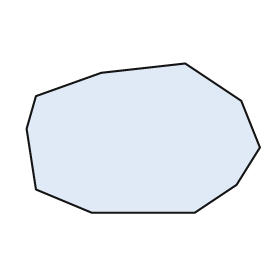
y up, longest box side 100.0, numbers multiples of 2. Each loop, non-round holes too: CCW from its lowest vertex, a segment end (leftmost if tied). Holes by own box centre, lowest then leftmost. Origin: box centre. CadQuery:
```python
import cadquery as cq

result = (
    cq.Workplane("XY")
    .moveTo(-22.0, -32.0)
    .lineTo(22.0, -32.0)
    .lineTo(40.0, -20.0)
    .lineTo(50.0, -4.0)
    .lineTo(42.0, 16.0)
    .lineTo(18.0, 32.0)
    .lineTo(-18.0, 28.0)
    .lineTo(-46.0, 18.0)
    .lineTo(-50.0, 4.0)
    .lineTo(-46.0, -22.0)
    .close()
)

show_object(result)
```